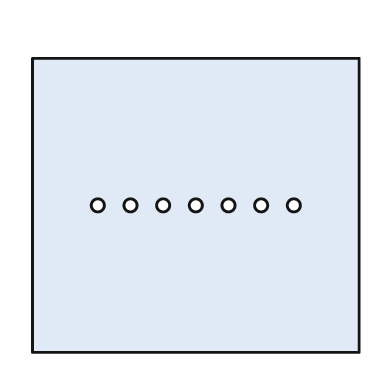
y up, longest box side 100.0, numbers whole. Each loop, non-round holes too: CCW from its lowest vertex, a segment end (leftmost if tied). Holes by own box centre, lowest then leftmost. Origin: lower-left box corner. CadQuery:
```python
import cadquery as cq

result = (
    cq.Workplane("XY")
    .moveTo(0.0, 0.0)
    .lineTo(100.0, 0.0)
    .lineTo(100.0, 90.0)
    .lineTo(0.0, 90.0)
    .close()
    .moveTo(20.0, 45.0)
    .circle(2.0)
    .moveTo(30.0, 45.0)
    .circle(2.0)
    .moveTo(40.0, 45.0)
    .circle(2.0)
    .moveTo(50.0, 45.0)
    .circle(2.0)
    .moveTo(60.0, 45.0)
    .circle(2.0)
    .moveTo(70.0, 45.0)
    .circle(2.0)
    .moveTo(80.0, 45.0)
    .circle(2.0)
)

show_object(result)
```